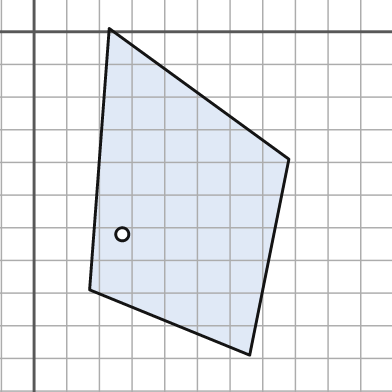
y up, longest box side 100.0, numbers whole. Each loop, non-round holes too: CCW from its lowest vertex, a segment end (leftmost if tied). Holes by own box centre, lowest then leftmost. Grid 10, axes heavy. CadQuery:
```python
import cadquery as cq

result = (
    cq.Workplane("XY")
    .moveTo(66.0, -99.0)
    .lineTo(78.0, -39.0)
    .lineTo(23.0, 1.0)
    .lineTo(17.0, -79.0)
    .close()
    .moveTo(27.0, -62.0)
    .circle(2.0)
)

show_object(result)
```